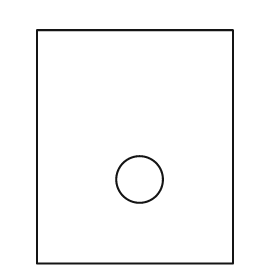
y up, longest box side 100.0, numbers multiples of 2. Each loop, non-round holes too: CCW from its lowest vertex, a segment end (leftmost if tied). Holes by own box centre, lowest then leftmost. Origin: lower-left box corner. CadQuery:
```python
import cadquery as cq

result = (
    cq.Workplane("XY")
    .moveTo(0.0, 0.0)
    .lineTo(84.0, 0.0)
    .lineTo(84.0, 100.0)
    .lineTo(0.0, 100.0)
    .close()
    .moveTo(44.0, 36.0)
    .circle(10.0)
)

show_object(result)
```